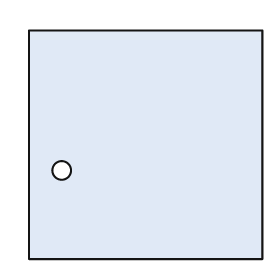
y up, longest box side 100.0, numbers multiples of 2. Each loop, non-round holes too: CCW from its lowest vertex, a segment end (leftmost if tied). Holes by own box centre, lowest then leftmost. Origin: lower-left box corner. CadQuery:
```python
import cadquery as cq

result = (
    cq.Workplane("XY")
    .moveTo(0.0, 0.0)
    .lineTo(100.0, 0.0)
    .lineTo(100.0, 98.0)
    .lineTo(0.0, 98.0)
    .close()
    .moveTo(14.0, 38.0)
    .circle(4.0)
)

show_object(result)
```